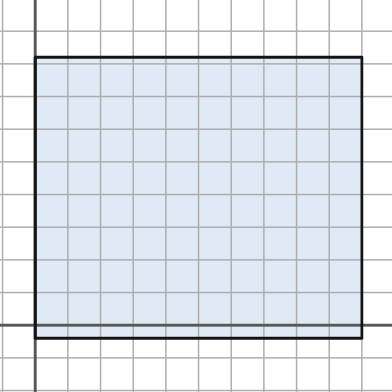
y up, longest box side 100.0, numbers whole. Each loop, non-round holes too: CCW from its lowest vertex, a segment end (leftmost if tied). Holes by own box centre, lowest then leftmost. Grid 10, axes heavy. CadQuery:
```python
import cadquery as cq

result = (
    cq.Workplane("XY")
    .moveTo(0.0, -4.0)
    .lineTo(100.0, -4.0)
    .lineTo(100.0, 82.0)
    .lineTo(0.0, 82.0)
    .close()
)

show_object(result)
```